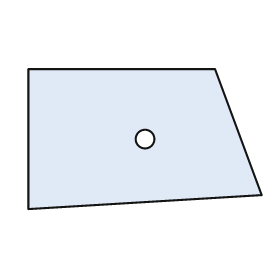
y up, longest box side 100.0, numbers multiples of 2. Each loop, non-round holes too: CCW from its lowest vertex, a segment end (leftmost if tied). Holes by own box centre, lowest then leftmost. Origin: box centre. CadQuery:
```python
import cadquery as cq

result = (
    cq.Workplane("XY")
    .moveTo(-50.0, -30.0)
    .lineTo(50.0, -24.0)
    .lineTo(30.0, 30.0)
    .lineTo(-50.0, 30.0)
    .close()
    .moveTo(0.0, 0.0)
    .circle(4.0)
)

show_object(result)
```